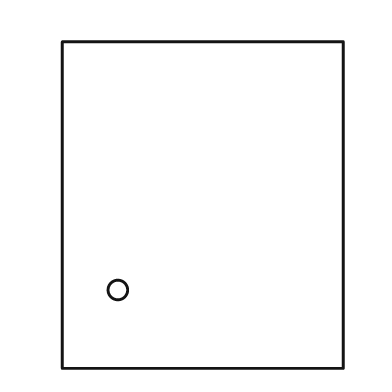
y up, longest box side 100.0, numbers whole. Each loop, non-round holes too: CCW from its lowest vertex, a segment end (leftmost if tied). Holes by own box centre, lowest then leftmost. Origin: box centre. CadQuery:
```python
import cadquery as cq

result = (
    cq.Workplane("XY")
    .moveTo(-43.0, -50.0)
    .lineTo(43.0, -50.0)
    .lineTo(43.0, 50.0)
    .lineTo(-43.0, 50.0)
    .close()
    .moveTo(-26.0, -26.0)
    .circle(3.0)
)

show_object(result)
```